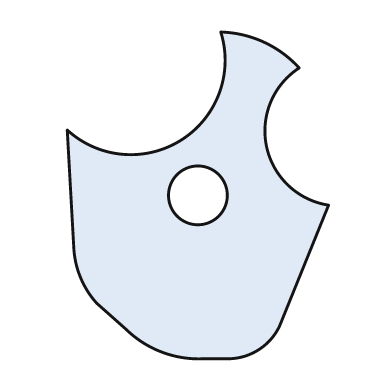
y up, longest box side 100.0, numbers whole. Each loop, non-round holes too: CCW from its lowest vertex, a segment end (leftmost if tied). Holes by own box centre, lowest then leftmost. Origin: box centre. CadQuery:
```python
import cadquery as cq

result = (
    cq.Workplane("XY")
    .moveTo(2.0, -50.0)
    .lineTo(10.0, -50.0)
    .threePointArc((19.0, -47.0), (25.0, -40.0))
    .lineTo(40.0, -3.0)
    .threePointArc((21.0, 15.0), (31.0, 39.0))
    .threePointArc((20.0, 47.0), (7.0, 50.0))
    .threePointArc((-5.0, 17.0), (-40.0, 20.0))
    .lineTo(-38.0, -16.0)
    .threePointArc((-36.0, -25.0), (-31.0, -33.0))
    .lineTo(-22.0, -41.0)
    .threePointArc((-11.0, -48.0), (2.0, -50.0))
    .close()
    .moveTo(0.0, 0.0)
    .circle(9.0)
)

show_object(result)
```